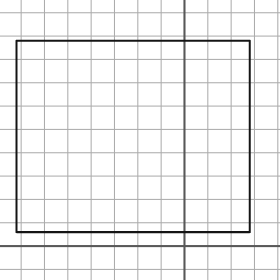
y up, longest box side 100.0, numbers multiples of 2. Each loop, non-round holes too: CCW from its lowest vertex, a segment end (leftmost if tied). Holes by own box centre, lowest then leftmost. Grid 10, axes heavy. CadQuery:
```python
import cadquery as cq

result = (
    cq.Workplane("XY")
    .moveTo(-72.0, 6.0)
    .lineTo(28.0, 6.0)
    .lineTo(28.0, 88.0)
    .lineTo(-72.0, 88.0)
    .close()
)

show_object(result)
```